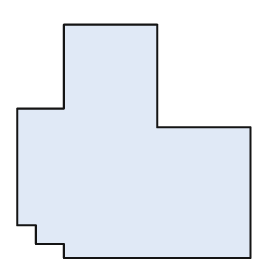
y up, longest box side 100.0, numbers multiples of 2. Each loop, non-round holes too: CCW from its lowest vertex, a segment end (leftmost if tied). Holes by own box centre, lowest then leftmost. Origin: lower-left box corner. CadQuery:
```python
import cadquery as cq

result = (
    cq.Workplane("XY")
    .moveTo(20.0, 0.0)
    .lineTo(100.0, 0.0)
    .lineTo(100.0, 56.0)
    .lineTo(60.0, 56.0)
    .lineTo(60.0, 100.0)
    .lineTo(20.0, 100.0)
    .lineTo(20.0, 64.0)
    .lineTo(0.0, 64.0)
    .lineTo(0.0, 14.0)
    .lineTo(8.0, 14.0)
    .lineTo(8.0, 6.0)
    .lineTo(20.0, 6.0)
    .close()
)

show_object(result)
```